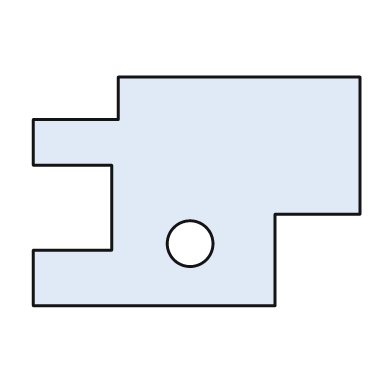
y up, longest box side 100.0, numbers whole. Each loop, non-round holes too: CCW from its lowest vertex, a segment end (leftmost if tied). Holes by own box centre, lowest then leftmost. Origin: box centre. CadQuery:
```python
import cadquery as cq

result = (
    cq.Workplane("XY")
    .moveTo(-50.0, -35.0)
    .lineTo(24.0, -35.0)
    .lineTo(24.0, -7.0)
    .lineTo(50.0, -7.0)
    .lineTo(50.0, 35.0)
    .lineTo(-24.0, 35.0)
    .lineTo(-24.0, 22.0)
    .lineTo(-50.0, 22.0)
    .lineTo(-50.0, 8.0)
    .lineTo(-26.0, 8.0)
    .lineTo(-26.0, -18.0)
    .lineTo(-50.0, -18.0)
    .close()
    .moveTo(-2.0, -16.0)
    .circle(7.0)
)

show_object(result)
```